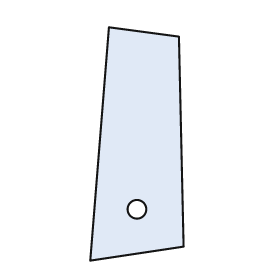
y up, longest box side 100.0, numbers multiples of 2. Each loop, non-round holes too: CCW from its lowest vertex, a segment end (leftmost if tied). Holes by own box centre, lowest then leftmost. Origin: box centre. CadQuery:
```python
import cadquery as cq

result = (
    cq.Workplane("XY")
    .moveTo(-20.0, -50.0)
    .lineTo(20.0, -44.0)
    .lineTo(18.0, 46.0)
    .lineTo(-12.0, 50.0)
    .close()
    .moveTo(0.0, -28.0)
    .circle(4.0)
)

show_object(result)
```